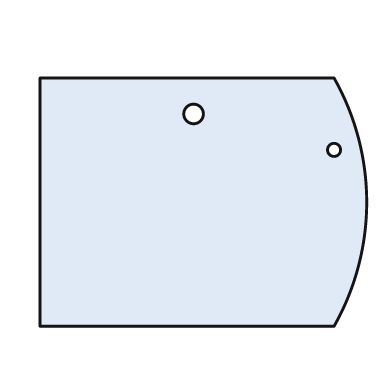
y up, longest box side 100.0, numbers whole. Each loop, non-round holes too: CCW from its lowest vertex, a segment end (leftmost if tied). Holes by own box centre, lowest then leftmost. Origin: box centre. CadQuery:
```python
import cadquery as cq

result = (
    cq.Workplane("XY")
    .moveTo(-50.0, -38.0)
    .lineTo(40.0, -38.0)
    .threePointArc((50.0, 0.0), (40.0, 38.0))
    .lineTo(-50.0, 38.0)
    .close()
    .moveTo(40.0, 16.0)
    .circle(2.0)
    .moveTo(-3.0, 27.0)
    .circle(3.0)
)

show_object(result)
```